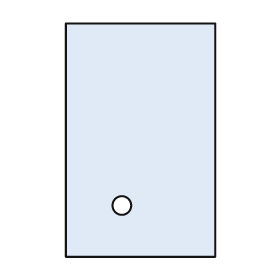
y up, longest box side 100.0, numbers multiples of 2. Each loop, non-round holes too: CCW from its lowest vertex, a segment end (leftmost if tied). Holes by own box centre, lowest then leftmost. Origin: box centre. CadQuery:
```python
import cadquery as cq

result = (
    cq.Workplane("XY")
    .moveTo(-32.0, -50.0)
    .lineTo(32.0, -50.0)
    .lineTo(32.0, 50.0)
    .lineTo(-32.0, 50.0)
    .close()
    .moveTo(-8.0, -28.0)
    .circle(4.0)
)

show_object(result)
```